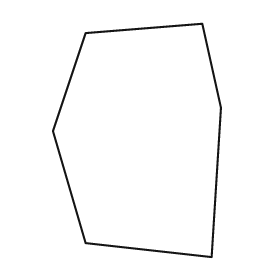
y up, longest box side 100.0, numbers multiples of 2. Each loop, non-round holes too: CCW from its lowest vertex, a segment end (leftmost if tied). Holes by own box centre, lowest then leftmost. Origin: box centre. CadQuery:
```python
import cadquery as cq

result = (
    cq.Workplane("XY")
    .moveTo(32.0, -50.0)
    .lineTo(36.0, 14.0)
    .lineTo(28.0, 50.0)
    .lineTo(-22.0, 46.0)
    .lineTo(-36.0, 4.0)
    .lineTo(-22.0, -44.0)
    .close()
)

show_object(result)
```